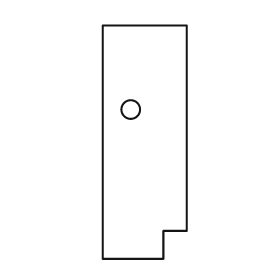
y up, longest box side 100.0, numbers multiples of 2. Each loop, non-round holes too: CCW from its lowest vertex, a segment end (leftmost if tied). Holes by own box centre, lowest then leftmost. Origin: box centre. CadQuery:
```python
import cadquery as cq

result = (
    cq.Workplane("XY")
    .moveTo(-18.0, -50.0)
    .lineTo(8.0, -50.0)
    .lineTo(8.0, -38.0)
    .lineTo(18.0, -38.0)
    .lineTo(18.0, 50.0)
    .lineTo(-18.0, 50.0)
    .close()
    .moveTo(-6.0, 14.0)
    .circle(4.0)
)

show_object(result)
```